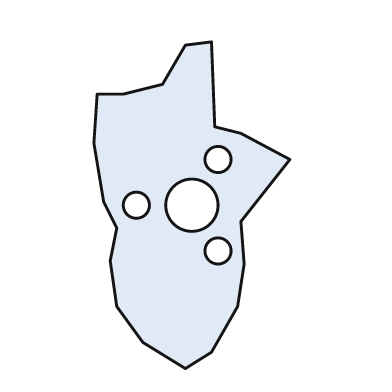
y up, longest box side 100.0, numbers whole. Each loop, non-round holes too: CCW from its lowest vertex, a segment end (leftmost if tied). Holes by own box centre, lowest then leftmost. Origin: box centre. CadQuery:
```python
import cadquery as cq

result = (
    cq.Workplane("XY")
    .moveTo(-2.0, -50.0)
    .lineTo(6.0, -45.0)
    .lineTo(14.0, -31.0)
    .lineTo(16.0, -18.0)
    .lineTo(15.0, -5.0)
    .lineTo(30.0, 14.0)
    .lineTo(15.0, 22.0)
    .lineTo(7.0, 24.0)
    .lineTo(6.0, 50.0)
    .lineTo(-2.0, 49.0)
    .lineTo(-9.0, 37.0)
    .lineTo(-21.0, 34.0)
    .lineTo(-29.0, 34.0)
    .lineTo(-30.0, 19.0)
    .lineTo(-27.0, 1.0)
    .lineTo(-23.0, -7.0)
    .lineTo(-25.0, -17.0)
    .lineTo(-23.0, -31.0)
    .lineTo(-15.0, -42.0)
    .close()
    .moveTo(8.0, -14.0)
    .circle(4.0)
    .moveTo(-17.0, 0.0)
    .circle(4.0)
    .moveTo(0.0, 0.0)
    .circle(8.0)
    .moveTo(8.0, 14.0)
    .circle(4.0)
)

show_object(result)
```